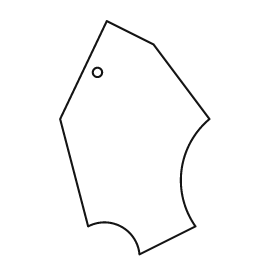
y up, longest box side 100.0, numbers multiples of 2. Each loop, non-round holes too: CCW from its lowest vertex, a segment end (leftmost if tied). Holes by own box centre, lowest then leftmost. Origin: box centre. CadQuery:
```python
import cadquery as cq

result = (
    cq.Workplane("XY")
    .moveTo(2.0, -50.0)
    .lineTo(26.0, -38.0)
    .threePointArc((20.0, -14.0), (32.0, 8.0))
    .lineTo(8.0, 40.0)
    .lineTo(-12.0, 50.0)
    .lineTo(-32.0, 8.0)
    .lineTo(-20.0, -38.0)
    .threePointArc((-6.0, -38.0), (2.0, -50.0))
    .close()
    .moveTo(-16.0, 28.0)
    .circle(2.0)
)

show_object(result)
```